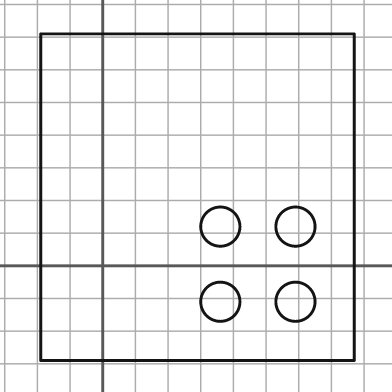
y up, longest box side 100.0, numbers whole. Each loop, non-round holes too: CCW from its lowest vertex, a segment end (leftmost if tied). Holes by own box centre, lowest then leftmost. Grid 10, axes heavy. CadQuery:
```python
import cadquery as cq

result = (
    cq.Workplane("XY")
    .moveTo(-19.0, -29.0)
    .lineTo(77.0, -29.0)
    .lineTo(77.0, 71.0)
    .lineTo(-19.0, 71.0)
    .close()
    .moveTo(36.0, -11.0)
    .circle(6.0)
    .moveTo(59.0, -11.0)
    .circle(6.0)
    .moveTo(36.0, 12.0)
    .circle(6.0)
    .moveTo(59.0, 12.0)
    .circle(6.0)
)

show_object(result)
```